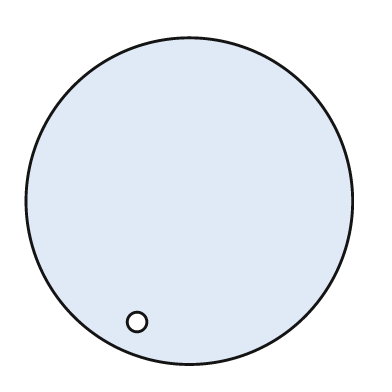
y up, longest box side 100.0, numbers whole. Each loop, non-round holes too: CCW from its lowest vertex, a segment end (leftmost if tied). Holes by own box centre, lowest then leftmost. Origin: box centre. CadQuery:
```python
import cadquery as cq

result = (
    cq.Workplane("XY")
    .moveTo(0.0, 0.0)
    .circle(50.0)
    .moveTo(-16.0, -37.0)
    .circle(3.0)
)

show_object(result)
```